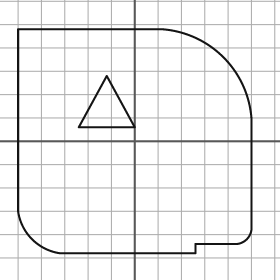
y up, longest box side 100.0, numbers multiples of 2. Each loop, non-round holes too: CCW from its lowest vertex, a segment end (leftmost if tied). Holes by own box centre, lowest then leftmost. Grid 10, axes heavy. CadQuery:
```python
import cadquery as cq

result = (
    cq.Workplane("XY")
    .moveTo(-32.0, -48.0)
    .lineTo(26.0, -48.0)
    .lineTo(26.0, -44.0)
    .lineTo(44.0, -44.0)
    .threePointArc((48.0, -42.0), (50.0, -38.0))
    .lineTo(50.0, 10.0)
    .threePointArc((38.0, 36.0), (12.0, 48.0))
    .lineTo(-50.0, 48.0)
    .lineTo(-50.0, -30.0)
    .threePointArc((-44.0, -42.0), (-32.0, -48.0))
    .close()
    .moveTo(-24.0, 6.0)
    .lineTo(0.0, 6.0)
    .lineTo(-12.0, 28.0)
    .close()
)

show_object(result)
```